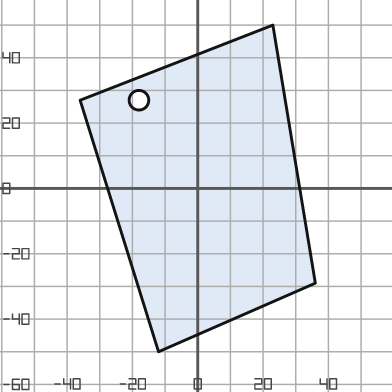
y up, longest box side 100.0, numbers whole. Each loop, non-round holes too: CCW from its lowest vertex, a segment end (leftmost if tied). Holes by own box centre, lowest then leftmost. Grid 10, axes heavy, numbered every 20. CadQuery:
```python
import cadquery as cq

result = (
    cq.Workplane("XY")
    .moveTo(-12.0, -50.0)
    .lineTo(36.0, -29.0)
    .lineTo(23.0, 50.0)
    .lineTo(-36.0, 27.0)
    .close()
    .moveTo(-18.0, 27.0)
    .circle(3.0)
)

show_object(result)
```